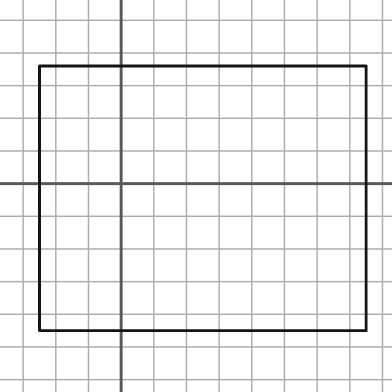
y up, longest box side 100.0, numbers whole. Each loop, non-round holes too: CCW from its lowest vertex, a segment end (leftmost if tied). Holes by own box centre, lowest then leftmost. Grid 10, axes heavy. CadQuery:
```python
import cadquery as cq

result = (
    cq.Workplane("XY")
    .moveTo(-25.0, -45.0)
    .lineTo(75.0, -45.0)
    .lineTo(75.0, 36.0)
    .lineTo(-25.0, 36.0)
    .close()
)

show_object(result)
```